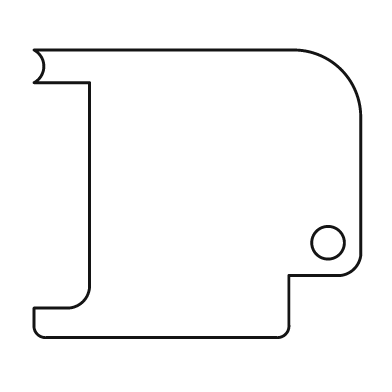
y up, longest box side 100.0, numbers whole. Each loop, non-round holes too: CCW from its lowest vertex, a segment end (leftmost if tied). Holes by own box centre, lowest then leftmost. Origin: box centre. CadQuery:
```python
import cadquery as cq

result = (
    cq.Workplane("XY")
    .moveTo(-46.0, -44.0)
    .lineTo(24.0, -44.0)
    .threePointArc((27.0, -43.0), (28.0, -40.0))
    .lineTo(28.0, -25.0)
    .lineTo(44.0, -25.0)
    .threePointArc((48.0, -23.0), (50.0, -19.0))
    .lineTo(50.0, 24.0)
    .threePointArc((44.0, 38.0), (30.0, 44.0))
    .lineTo(-50.0, 44.0)
    .threePointArc((-47.0, 39.0), (-50.0, 34.0))
    .lineTo(-33.0, 34.0)
    .lineTo(-33.0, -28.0)
    .threePointArc((-35.0, -33.0), (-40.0, -35.0))
    .lineTo(-50.0, -35.0)
    .lineTo(-50.0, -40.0)
    .threePointArc((-49.0, -43.0), (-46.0, -44.0))
    .close()
    .moveTo(40.0, -15.0)
    .circle(5.0)
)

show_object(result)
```